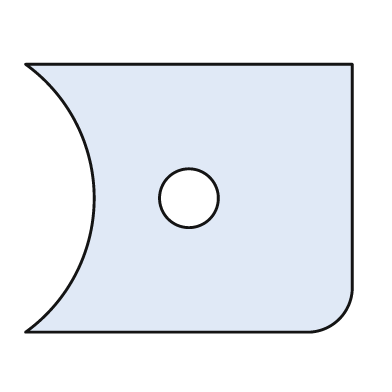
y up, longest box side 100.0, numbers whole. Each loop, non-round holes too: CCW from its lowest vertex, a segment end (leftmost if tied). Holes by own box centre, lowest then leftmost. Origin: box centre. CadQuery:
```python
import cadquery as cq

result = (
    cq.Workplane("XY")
    .moveTo(-50.0, -41.0)
    .lineTo(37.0, -41.0)
    .threePointArc((46.0, -37.0), (50.0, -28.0))
    .lineTo(50.0, 41.0)
    .lineTo(-50.0, 41.0)
    .threePointArc((-29.0, 0.0), (-50.0, -41.0))
    .close()
    .moveTo(0.0, 0.0)
    .circle(9.0)
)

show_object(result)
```